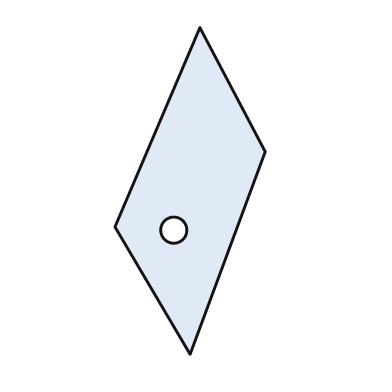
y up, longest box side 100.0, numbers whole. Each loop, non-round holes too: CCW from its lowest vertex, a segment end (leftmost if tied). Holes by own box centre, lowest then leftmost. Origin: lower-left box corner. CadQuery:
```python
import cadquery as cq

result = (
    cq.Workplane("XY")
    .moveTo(23.0, 0.0)
    .lineTo(46.0, 62.0)
    .lineTo(26.0, 100.0)
    .lineTo(0.0, 39.0)
    .close()
    .moveTo(18.0, 38.0)
    .circle(4.0)
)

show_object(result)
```